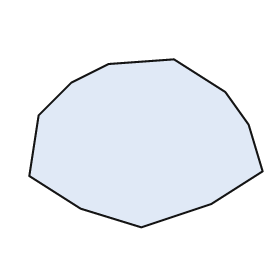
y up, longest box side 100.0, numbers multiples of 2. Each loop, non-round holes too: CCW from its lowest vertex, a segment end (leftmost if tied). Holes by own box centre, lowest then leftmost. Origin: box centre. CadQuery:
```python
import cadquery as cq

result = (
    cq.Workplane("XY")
    .moveTo(-2.0, -36.0)
    .lineTo(28.0, -26.0)
    .lineTo(50.0, -12.0)
    .lineTo(44.0, 8.0)
    .lineTo(34.0, 22.0)
    .lineTo(12.0, 36.0)
    .lineTo(-16.0, 34.0)
    .lineTo(-32.0, 26.0)
    .lineTo(-46.0, 12.0)
    .lineTo(-50.0, -14.0)
    .lineTo(-28.0, -28.0)
    .close()
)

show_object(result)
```